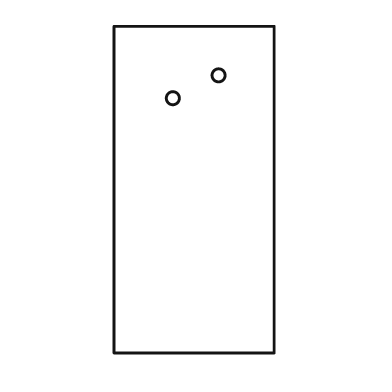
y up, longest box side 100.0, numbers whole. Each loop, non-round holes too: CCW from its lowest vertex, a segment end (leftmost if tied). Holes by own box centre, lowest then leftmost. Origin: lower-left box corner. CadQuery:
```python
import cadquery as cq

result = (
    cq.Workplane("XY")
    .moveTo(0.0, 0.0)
    .lineTo(49.0, 0.0)
    .lineTo(49.0, 100.0)
    .lineTo(0.0, 100.0)
    .close()
    .moveTo(18.0, 78.0)
    .circle(2.0)
    .moveTo(32.0, 85.0)
    .circle(2.0)
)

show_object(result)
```